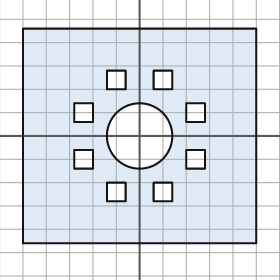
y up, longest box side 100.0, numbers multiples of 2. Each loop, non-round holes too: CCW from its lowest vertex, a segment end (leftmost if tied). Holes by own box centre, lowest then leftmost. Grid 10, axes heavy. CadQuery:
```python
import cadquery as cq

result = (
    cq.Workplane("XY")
    .moveTo(-50.0, -46.0)
    .lineTo(50.0, -46.0)
    .lineTo(50.0, 46.0)
    .lineTo(-50.0, 46.0)
    .close()
    .moveTo(-14.0, -28.0)
    .lineTo(-6.0, -28.0)
    .lineTo(-6.0, -20.0)
    .lineTo(-14.0, -20.0)
    .close()
    .moveTo(6.0, -28.0)
    .lineTo(14.0, -28.0)
    .lineTo(14.0, -20.0)
    .lineTo(6.0, -20.0)
    .close()
    .moveTo(-28.0, -14.0)
    .lineTo(-20.0, -14.0)
    .lineTo(-20.0, -6.0)
    .lineTo(-28.0, -6.0)
    .close()
    .moveTo(20.0, -14.0)
    .lineTo(28.0, -14.0)
    .lineTo(28.0, -6.0)
    .lineTo(20.0, -6.0)
    .close()
    .moveTo(0.0, 0.0)
    .circle(14.0)
    .moveTo(-28.0, 6.0)
    .lineTo(-20.0, 6.0)
    .lineTo(-20.0, 14.0)
    .lineTo(-28.0, 14.0)
    .close()
    .moveTo(20.0, 6.0)
    .lineTo(28.0, 6.0)
    .lineTo(28.0, 14.0)
    .lineTo(20.0, 14.0)
    .close()
    .moveTo(-14.0, 20.0)
    .lineTo(-6.0, 20.0)
    .lineTo(-6.0, 28.0)
    .lineTo(-14.0, 28.0)
    .close()
    .moveTo(6.0, 20.0)
    .lineTo(14.0, 20.0)
    .lineTo(14.0, 28.0)
    .lineTo(6.0, 28.0)
    .close()
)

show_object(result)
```